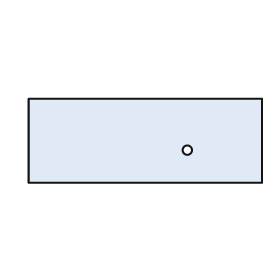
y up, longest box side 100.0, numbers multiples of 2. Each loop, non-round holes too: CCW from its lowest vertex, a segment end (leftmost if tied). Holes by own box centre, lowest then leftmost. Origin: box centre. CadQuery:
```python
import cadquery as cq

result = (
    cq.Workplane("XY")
    .moveTo(-50.0, -18.0)
    .lineTo(50.0, -18.0)
    .lineTo(50.0, 18.0)
    .lineTo(-50.0, 18.0)
    .close()
    .moveTo(18.0, -4.0)
    .circle(2.0)
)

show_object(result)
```